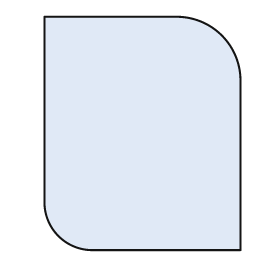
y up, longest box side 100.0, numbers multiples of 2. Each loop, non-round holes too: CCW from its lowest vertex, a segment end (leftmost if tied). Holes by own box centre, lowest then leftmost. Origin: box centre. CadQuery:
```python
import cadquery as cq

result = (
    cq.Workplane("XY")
    .moveTo(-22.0, -50.0)
    .lineTo(42.0, -50.0)
    .lineTo(42.0, 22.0)
    .threePointArc((34.0, 42.0), (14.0, 50.0))
    .lineTo(-42.0, 50.0)
    .lineTo(-42.0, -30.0)
    .threePointArc((-36.0, -44.0), (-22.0, -50.0))
    .close()
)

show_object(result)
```